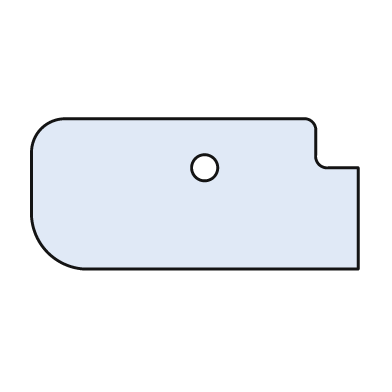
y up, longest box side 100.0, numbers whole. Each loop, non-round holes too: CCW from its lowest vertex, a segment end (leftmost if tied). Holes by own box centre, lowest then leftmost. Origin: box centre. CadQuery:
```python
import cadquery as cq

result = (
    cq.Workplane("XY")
    .moveTo(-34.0, -23.0)
    .lineTo(50.0, -23.0)
    .lineTo(50.0, 8.0)
    .lineTo(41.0, 8.0)
    .threePointArc((38.0, 9.0), (37.0, 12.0))
    .lineTo(37.0, 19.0)
    .threePointArc((36.0, 22.0), (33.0, 23.0))
    .lineTo(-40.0, 23.0)
    .threePointArc((-47.0, 20.0), (-50.0, 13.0))
    .lineTo(-50.0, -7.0)
    .threePointArc((-45.0, -18.0), (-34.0, -23.0))
    .close()
    .moveTo(3.0, 8.0)
    .circle(4.0)
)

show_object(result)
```